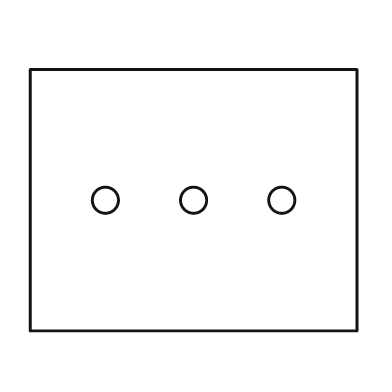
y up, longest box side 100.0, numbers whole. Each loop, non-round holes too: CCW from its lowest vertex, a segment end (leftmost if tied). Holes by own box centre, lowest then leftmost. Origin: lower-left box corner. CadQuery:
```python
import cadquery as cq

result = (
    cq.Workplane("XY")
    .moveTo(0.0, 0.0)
    .lineTo(100.0, 0.0)
    .lineTo(100.0, 80.0)
    .lineTo(0.0, 80.0)
    .close()
    .moveTo(23.0, 40.0)
    .circle(4.0)
    .moveTo(50.0, 40.0)
    .circle(4.0)
    .moveTo(77.0, 40.0)
    .circle(4.0)
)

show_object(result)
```